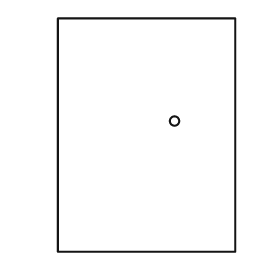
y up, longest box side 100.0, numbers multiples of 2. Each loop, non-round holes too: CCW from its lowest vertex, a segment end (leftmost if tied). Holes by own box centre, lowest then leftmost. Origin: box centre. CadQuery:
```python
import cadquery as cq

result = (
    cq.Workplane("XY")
    .moveTo(-38.0, -50.0)
    .lineTo(38.0, -50.0)
    .lineTo(38.0, 50.0)
    .lineTo(-38.0, 50.0)
    .close()
    .moveTo(12.0, 6.0)
    .circle(2.0)
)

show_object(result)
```